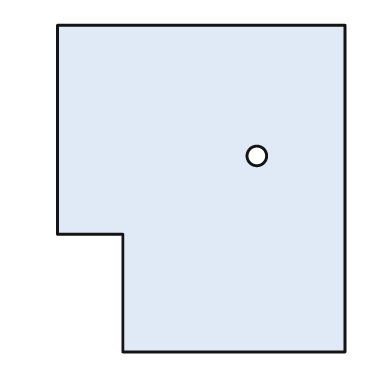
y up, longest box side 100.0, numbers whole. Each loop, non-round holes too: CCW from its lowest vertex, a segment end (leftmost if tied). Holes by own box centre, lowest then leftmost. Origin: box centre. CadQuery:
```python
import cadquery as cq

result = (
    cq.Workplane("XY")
    .moveTo(-24.0, -50.0)
    .lineTo(44.0, -50.0)
    .lineTo(44.0, 50.0)
    .lineTo(-44.0, 50.0)
    .lineTo(-44.0, -14.0)
    .lineTo(-24.0, -14.0)
    .close()
    .moveTo(17.0, 10.0)
    .circle(3.0)
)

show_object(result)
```